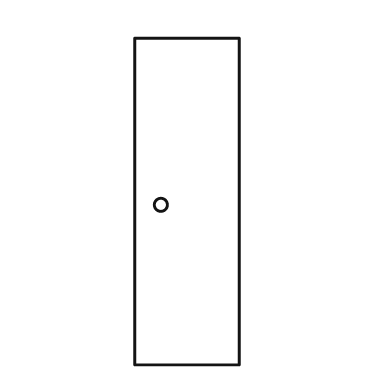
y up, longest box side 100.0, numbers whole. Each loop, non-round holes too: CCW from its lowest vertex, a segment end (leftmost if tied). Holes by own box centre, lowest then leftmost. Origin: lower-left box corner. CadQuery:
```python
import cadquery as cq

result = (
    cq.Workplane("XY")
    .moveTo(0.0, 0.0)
    .lineTo(32.0, 0.0)
    .lineTo(32.0, 100.0)
    .lineTo(0.0, 100.0)
    .close()
    .moveTo(8.0, 49.0)
    .circle(2.0)
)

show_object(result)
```